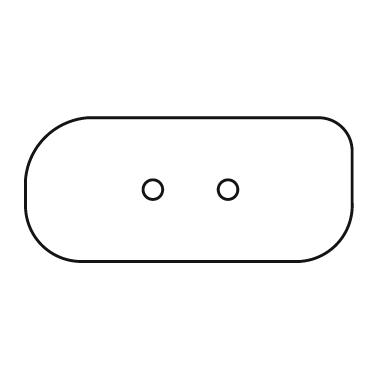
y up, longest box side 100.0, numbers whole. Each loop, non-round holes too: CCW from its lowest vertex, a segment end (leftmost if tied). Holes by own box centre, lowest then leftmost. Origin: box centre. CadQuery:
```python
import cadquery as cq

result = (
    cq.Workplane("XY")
    .moveTo(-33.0, -22.0)
    .lineTo(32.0, -22.0)
    .threePointArc((45.0, -17.0), (50.0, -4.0))
    .lineTo(50.0, 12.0)
    .threePointArc((47.0, 19.0), (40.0, 22.0))
    .lineTo(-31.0, 22.0)
    .threePointArc((-44.0, 16.0), (-50.0, 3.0))
    .lineTo(-50.0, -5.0)
    .threePointArc((-45.0, -17.0), (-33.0, -22.0))
    .close()
    .moveTo(-11.0, 0.0)
    .circle(3.0)
    .moveTo(12.0, 0.0)
    .circle(3.0)
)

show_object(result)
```